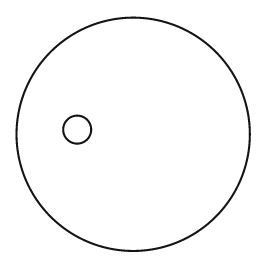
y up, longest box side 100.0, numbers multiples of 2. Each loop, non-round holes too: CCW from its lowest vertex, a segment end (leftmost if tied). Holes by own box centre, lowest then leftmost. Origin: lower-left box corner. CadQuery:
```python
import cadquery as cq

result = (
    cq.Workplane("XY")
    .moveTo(50.0, 50.0)
    .circle(50.0)
    .moveTo(26.0, 52.0)
    .circle(6.0)
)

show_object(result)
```